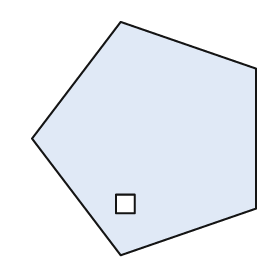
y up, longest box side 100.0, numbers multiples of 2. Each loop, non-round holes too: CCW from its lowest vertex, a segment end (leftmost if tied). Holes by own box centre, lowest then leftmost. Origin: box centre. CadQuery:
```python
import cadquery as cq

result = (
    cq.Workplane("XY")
    .moveTo(-10.0, -50.0)
    .lineTo(48.0, -30.0)
    .lineTo(48.0, 30.0)
    .lineTo(-10.0, 50.0)
    .lineTo(-48.0, 0.0)
    .close()
    .moveTo(-12.0, -32.0)
    .lineTo(-4.0, -32.0)
    .lineTo(-4.0, -24.0)
    .lineTo(-12.0, -24.0)
    .close()
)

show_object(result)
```